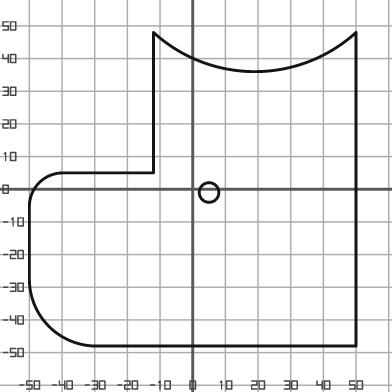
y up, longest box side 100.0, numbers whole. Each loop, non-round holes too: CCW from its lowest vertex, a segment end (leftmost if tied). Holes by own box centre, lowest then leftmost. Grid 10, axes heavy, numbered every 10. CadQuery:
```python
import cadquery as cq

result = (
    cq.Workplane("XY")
    .moveTo(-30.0, -48.0)
    .lineTo(50.0, -48.0)
    .lineTo(50.0, 48.0)
    .threePointArc((19.0, 36.0), (-12.0, 48.0))
    .lineTo(-12.0, 5.0)
    .lineTo(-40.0, 5.0)
    .threePointArc((-47.0, 2.0), (-50.0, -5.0))
    .lineTo(-50.0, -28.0)
    .threePointArc((-44.0, -42.0), (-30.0, -48.0))
    .close()
    .moveTo(5.0, -1.0)
    .circle(3.0)
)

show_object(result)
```